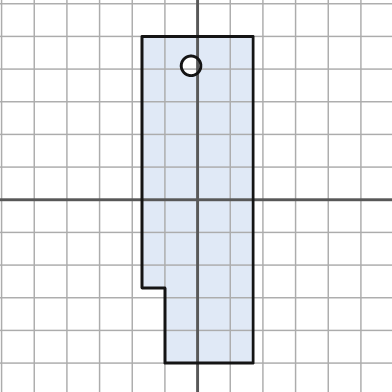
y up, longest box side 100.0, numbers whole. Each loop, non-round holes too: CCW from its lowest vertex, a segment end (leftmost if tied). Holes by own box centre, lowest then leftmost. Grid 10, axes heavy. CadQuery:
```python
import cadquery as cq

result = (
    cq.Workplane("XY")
    .moveTo(-10.0, -50.0)
    .lineTo(17.0, -50.0)
    .lineTo(17.0, 50.0)
    .lineTo(-17.0, 50.0)
    .lineTo(-17.0, -27.0)
    .lineTo(-10.0, -27.0)
    .close()
    .moveTo(-2.0, 41.0)
    .circle(3.0)
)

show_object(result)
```